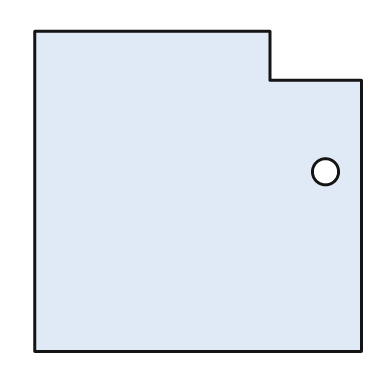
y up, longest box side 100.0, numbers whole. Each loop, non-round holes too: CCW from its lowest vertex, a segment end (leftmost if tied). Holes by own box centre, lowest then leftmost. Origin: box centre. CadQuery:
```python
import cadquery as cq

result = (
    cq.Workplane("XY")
    .moveTo(-50.0, -49.0)
    .lineTo(50.0, -49.0)
    .lineTo(50.0, 34.0)
    .lineTo(22.0, 34.0)
    .lineTo(22.0, 49.0)
    .lineTo(-50.0, 49.0)
    .close()
    .moveTo(39.0, 6.0)
    .circle(4.0)
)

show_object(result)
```